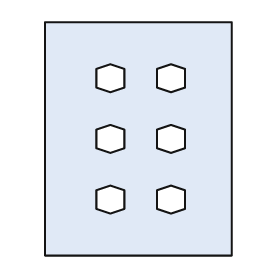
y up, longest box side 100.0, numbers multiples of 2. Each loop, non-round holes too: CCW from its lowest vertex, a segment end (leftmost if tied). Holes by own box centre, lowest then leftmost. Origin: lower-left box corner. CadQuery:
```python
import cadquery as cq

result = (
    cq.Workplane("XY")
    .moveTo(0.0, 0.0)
    .lineTo(80.0, 0.0)
    .lineTo(80.0, 100.0)
    .lineTo(0.0, 100.0)
    .close()
    .moveTo(28.0, 18.0)
    .lineTo(34.0, 20.0)
    .lineTo(34.0, 28.0)
    .lineTo(28.0, 30.0)
    .lineTo(22.0, 28.0)
    .lineTo(22.0, 20.0)
    .close()
    .moveTo(54.0, 18.0)
    .lineTo(60.0, 20.0)
    .lineTo(60.0, 28.0)
    .lineTo(54.0, 30.0)
    .lineTo(48.0, 28.0)
    .lineTo(48.0, 20.0)
    .close()
    .moveTo(28.0, 44.0)
    .lineTo(34.0, 46.0)
    .lineTo(34.0, 54.0)
    .lineTo(28.0, 56.0)
    .lineTo(22.0, 54.0)
    .lineTo(22.0, 46.0)
    .close()
    .moveTo(54.0, 44.0)
    .lineTo(60.0, 46.0)
    .lineTo(60.0, 54.0)
    .lineTo(54.0, 56.0)
    .lineTo(48.0, 54.0)
    .lineTo(48.0, 46.0)
    .close()
    .moveTo(28.0, 70.0)
    .lineTo(34.0, 72.0)
    .lineTo(34.0, 80.0)
    .lineTo(28.0, 82.0)
    .lineTo(22.0, 80.0)
    .lineTo(22.0, 72.0)
    .close()
    .moveTo(54.0, 70.0)
    .lineTo(60.0, 72.0)
    .lineTo(60.0, 80.0)
    .lineTo(54.0, 82.0)
    .lineTo(48.0, 80.0)
    .lineTo(48.0, 72.0)
    .close()
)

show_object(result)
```